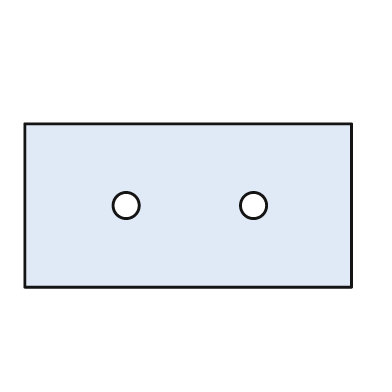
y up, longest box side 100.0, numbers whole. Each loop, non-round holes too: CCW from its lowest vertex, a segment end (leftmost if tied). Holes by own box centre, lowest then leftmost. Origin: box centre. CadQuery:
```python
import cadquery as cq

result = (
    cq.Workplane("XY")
    .moveTo(-50.0, -25.0)
    .lineTo(50.0, -25.0)
    .lineTo(50.0, 25.0)
    .lineTo(-50.0, 25.0)
    .close()
    .moveTo(-19.0, 0.0)
    .circle(4.0)
    .moveTo(20.0, 0.0)
    .circle(4.0)
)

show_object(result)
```